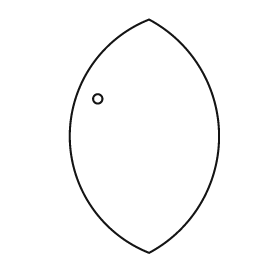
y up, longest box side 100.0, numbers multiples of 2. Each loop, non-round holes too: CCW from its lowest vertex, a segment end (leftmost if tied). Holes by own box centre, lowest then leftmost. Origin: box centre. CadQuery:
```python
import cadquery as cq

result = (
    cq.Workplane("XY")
    .moveTo(2.0, -50.0)
    .threePointArc((32.0, 0.0), (2.0, 50.0))
    .threePointArc((-32.0, 0.0), (2.0, -50.0))
    .close()
    .moveTo(-20.0, 16.0)
    .circle(2.0)
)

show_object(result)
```